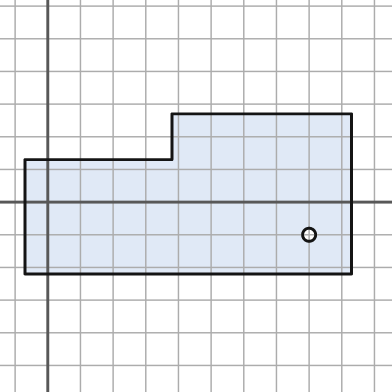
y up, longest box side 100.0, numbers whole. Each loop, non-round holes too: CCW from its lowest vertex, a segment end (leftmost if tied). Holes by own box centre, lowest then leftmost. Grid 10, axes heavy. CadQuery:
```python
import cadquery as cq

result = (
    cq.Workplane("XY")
    .moveTo(-7.0, -22.0)
    .lineTo(93.0, -22.0)
    .lineTo(93.0, 27.0)
    .lineTo(38.0, 27.0)
    .lineTo(38.0, 13.0)
    .lineTo(-7.0, 13.0)
    .close()
    .moveTo(80.0, -10.0)
    .circle(2.0)
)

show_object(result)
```